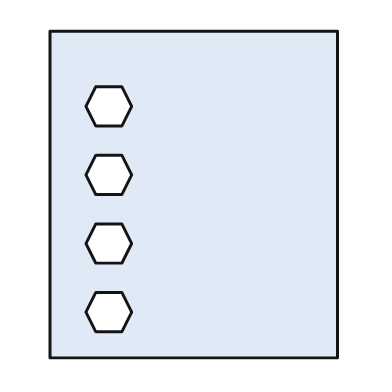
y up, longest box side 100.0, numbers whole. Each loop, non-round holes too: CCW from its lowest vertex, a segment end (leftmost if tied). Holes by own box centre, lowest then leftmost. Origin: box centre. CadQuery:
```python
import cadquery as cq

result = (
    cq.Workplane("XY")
    .moveTo(-44.0, -50.0)
    .lineTo(44.0, -50.0)
    .lineTo(44.0, 50.0)
    .lineTo(-44.0, 50.0)
    .close()
    .moveTo(-30.0, -42.0)
    .lineTo(-22.0, -42.0)
    .lineTo(-19.0, -36.0)
    .lineTo(-22.0, -30.0)
    .lineTo(-30.0, -30.0)
    .lineTo(-33.0, -36.0)
    .close()
    .moveTo(-30.0, -21.0)
    .lineTo(-22.0, -21.0)
    .lineTo(-19.0, -15.0)
    .lineTo(-22.0, -9.0)
    .lineTo(-30.0, -9.0)
    .lineTo(-33.0, -15.0)
    .close()
    .moveTo(-30.0, 0.0)
    .lineTo(-22.0, 0.0)
    .lineTo(-19.0, 6.0)
    .lineTo(-22.0, 12.0)
    .lineTo(-30.0, 12.0)
    .lineTo(-33.0, 6.0)
    .close()
    .moveTo(-30.0, 21.0)
    .lineTo(-22.0, 21.0)
    .lineTo(-19.0, 27.0)
    .lineTo(-22.0, 33.0)
    .lineTo(-30.0, 33.0)
    .lineTo(-33.0, 27.0)
    .close()
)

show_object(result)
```